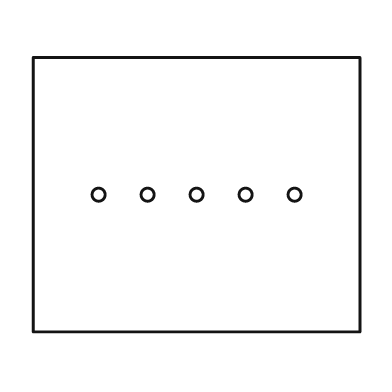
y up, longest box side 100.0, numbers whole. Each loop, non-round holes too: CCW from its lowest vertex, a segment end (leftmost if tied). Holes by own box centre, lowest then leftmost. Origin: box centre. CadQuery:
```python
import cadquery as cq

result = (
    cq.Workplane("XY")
    .moveTo(-50.0, -42.0)
    .lineTo(50.0, -42.0)
    .lineTo(50.0, 42.0)
    .lineTo(-50.0, 42.0)
    .close()
    .moveTo(-30.0, 0.0)
    .circle(2.0)
    .moveTo(-15.0, 0.0)
    .circle(2.0)
    .moveTo(0.0, 0.0)
    .circle(2.0)
    .moveTo(15.0, 0.0)
    .circle(2.0)
    .moveTo(30.0, 0.0)
    .circle(2.0)
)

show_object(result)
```